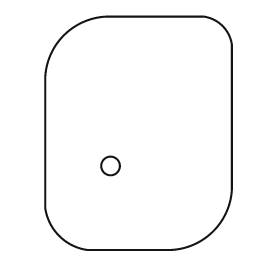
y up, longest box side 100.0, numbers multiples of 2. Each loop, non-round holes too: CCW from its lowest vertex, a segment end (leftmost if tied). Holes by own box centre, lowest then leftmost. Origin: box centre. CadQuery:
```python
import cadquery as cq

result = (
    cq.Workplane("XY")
    .moveTo(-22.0, -50.0)
    .lineTo(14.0, -50.0)
    .threePointArc((32.0, -42.0), (40.0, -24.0))
    .lineTo(40.0, 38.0)
    .threePointArc((36.0, 46.0), (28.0, 50.0))
    .lineTo(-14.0, 50.0)
    .threePointArc((-32.0, 42.0), (-40.0, 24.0))
    .lineTo(-40.0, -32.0)
    .threePointArc((-34.0, -44.0), (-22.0, -50.0))
    .close()
    .moveTo(-12.0, -14.0)
    .circle(4.0)
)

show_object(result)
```